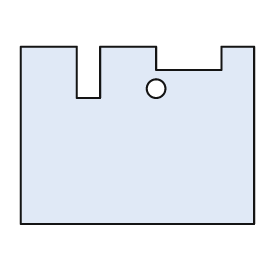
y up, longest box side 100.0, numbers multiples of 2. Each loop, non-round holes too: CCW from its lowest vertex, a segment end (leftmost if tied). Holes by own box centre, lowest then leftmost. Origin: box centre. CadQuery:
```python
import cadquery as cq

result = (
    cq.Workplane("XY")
    .moveTo(-50.0, -38.0)
    .lineTo(50.0, -38.0)
    .lineTo(50.0, 38.0)
    .lineTo(36.0, 38.0)
    .lineTo(36.0, 28.0)
    .lineTo(8.0, 28.0)
    .lineTo(8.0, 38.0)
    .lineTo(-16.0, 38.0)
    .lineTo(-16.0, 16.0)
    .lineTo(-26.0, 16.0)
    .lineTo(-26.0, 38.0)
    .lineTo(-50.0, 38.0)
    .close()
    .moveTo(8.0, 20.0)
    .circle(4.0)
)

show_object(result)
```